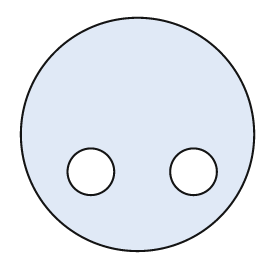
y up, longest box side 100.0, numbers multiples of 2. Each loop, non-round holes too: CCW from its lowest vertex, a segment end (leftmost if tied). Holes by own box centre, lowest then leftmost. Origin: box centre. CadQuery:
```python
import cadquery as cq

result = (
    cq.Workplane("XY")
    .moveTo(0.0, 0.0)
    .circle(50.0)
    .moveTo(-20.0, -16.0)
    .circle(10.0)
    .moveTo(24.0, -16.0)
    .circle(10.0)
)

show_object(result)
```